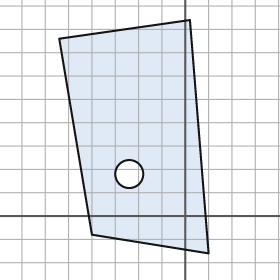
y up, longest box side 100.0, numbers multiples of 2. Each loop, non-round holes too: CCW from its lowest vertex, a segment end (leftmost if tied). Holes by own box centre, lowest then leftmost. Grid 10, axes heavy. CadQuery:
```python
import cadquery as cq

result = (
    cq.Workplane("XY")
    .moveTo(10.0, -16.0)
    .lineTo(2.0, 84.0)
    .lineTo(-54.0, 76.0)
    .lineTo(-40.0, -8.0)
    .close()
    .moveTo(-24.0, 18.0)
    .circle(6.0)
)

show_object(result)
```